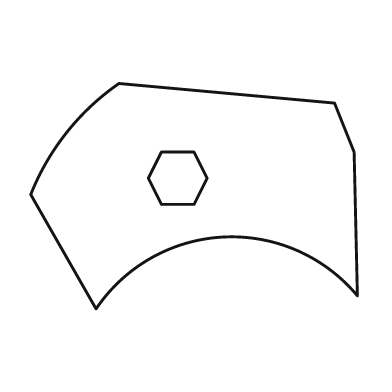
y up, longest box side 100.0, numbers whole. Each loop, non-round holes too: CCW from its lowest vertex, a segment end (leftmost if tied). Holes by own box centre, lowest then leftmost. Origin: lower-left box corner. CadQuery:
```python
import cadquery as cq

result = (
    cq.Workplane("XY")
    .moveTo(20.0, 0.0)
    .threePointArc((59.0, 22.0), (100.0, 4.0))
    .lineTo(99.0, 48.0)
    .lineTo(93.0, 63.0)
    .lineTo(27.0, 69.0)
    .threePointArc((11.0, 54.0), (0.0, 35.0))
    .close()
    .moveTo(40.0, 32.0)
    .lineTo(50.0, 32.0)
    .lineTo(54.0, 40.0)
    .lineTo(50.0, 48.0)
    .lineTo(40.0, 48.0)
    .lineTo(36.0, 40.0)
    .close()
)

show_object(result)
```